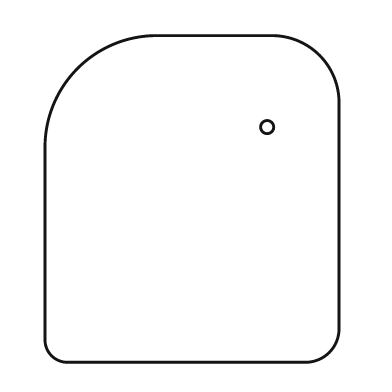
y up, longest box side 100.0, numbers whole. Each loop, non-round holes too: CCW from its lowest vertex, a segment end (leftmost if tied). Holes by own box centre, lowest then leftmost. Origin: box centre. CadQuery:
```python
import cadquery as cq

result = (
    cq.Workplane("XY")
    .moveTo(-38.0, -50.0)
    .lineTo(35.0, -50.0)
    .threePointArc((42.0, -47.0), (45.0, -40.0))
    .lineTo(45.0, 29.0)
    .threePointArc((39.0, 44.0), (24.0, 50.0))
    .lineTo(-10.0, 50.0)
    .threePointArc((-35.0, 40.0), (-45.0, 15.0))
    .lineTo(-45.0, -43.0)
    .threePointArc((-43.0, -48.0), (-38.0, -50.0))
    .close()
    .moveTo(23.0, 22.0)
    .circle(2.0)
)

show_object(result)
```